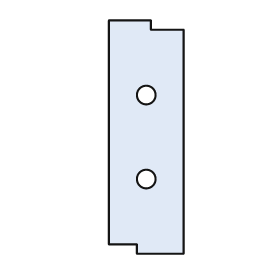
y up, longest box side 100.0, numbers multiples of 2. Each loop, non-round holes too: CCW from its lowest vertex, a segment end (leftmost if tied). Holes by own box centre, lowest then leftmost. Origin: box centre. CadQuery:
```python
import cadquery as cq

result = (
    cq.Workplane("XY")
    .moveTo(-4.0, -50.0)
    .lineTo(16.0, -50.0)
    .lineTo(16.0, 46.0)
    .lineTo(2.0, 46.0)
    .lineTo(2.0, 50.0)
    .lineTo(-16.0, 50.0)
    .lineTo(-16.0, -46.0)
    .lineTo(-4.0, -46.0)
    .close()
    .moveTo(0.0, -18.0)
    .circle(4.0)
    .moveTo(0.0, 18.0)
    .circle(4.0)
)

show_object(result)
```